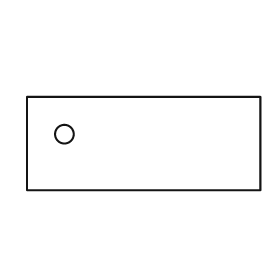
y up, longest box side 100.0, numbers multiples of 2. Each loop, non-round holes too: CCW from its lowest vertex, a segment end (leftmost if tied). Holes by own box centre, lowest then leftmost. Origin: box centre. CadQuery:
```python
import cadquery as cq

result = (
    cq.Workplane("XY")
    .moveTo(-50.0, -20.0)
    .lineTo(50.0, -20.0)
    .lineTo(50.0, 20.0)
    .lineTo(-50.0, 20.0)
    .close()
    .moveTo(-34.0, 4.0)
    .circle(4.0)
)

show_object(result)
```